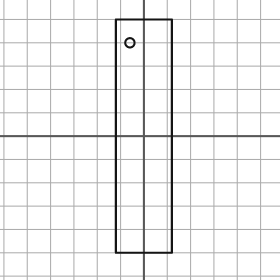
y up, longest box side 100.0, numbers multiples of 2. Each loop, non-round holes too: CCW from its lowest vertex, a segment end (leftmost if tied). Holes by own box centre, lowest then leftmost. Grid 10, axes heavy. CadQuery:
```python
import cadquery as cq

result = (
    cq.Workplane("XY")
    .moveTo(-12.0, -50.0)
    .lineTo(12.0, -50.0)
    .lineTo(12.0, 50.0)
    .lineTo(-12.0, 50.0)
    .close()
    .moveTo(-6.0, 40.0)
    .circle(2.0)
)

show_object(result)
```